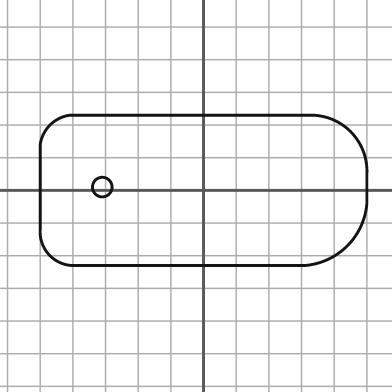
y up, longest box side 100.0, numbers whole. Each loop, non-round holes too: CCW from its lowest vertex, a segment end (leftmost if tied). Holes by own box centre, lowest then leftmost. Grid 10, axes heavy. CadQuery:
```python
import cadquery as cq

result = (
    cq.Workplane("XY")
    .moveTo(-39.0, -23.0)
    .lineTo(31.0, -23.0)
    .threePointArc((44.0, -17.0), (50.0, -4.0))
    .lineTo(50.0, 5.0)
    .threePointArc((45.0, 18.0), (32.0, 23.0))
    .lineTo(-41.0, 23.0)
    .threePointArc((-47.0, 20.0), (-50.0, 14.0))
    .lineTo(-50.0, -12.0)
    .threePointArc((-47.0, -20.0), (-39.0, -23.0))
    .close()
    .moveTo(-31.0, 1.0)
    .circle(3.0)
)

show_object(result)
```